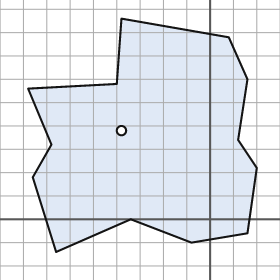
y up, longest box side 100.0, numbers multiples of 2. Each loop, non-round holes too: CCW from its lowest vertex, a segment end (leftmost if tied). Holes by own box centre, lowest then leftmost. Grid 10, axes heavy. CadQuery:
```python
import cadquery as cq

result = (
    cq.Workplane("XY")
    .moveTo(-66.0, -14.0)
    .lineTo(-34.0, 0.0)
    .lineTo(-8.0, -10.0)
    .lineTo(16.0, -6.0)
    .lineTo(20.0, 22.0)
    .lineTo(12.0, 34.0)
    .lineTo(16.0, 60.0)
    .lineTo(8.0, 78.0)
    .lineTo(-38.0, 86.0)
    .lineTo(-40.0, 58.0)
    .lineTo(-78.0, 56.0)
    .lineTo(-68.0, 32.0)
    .lineTo(-76.0, 18.0)
    .close()
    .moveTo(-38.0, 38.0)
    .circle(2.0)
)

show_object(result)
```